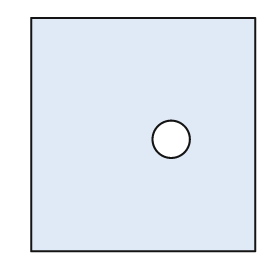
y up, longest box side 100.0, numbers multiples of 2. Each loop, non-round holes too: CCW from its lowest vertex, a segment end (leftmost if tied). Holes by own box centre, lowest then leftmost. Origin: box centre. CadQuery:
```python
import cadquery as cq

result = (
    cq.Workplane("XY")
    .moveTo(-48.0, -50.0)
    .lineTo(48.0, -50.0)
    .lineTo(48.0, 50.0)
    .lineTo(-48.0, 50.0)
    .close()
    .moveTo(12.0, -2.0)
    .circle(8.0)
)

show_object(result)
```